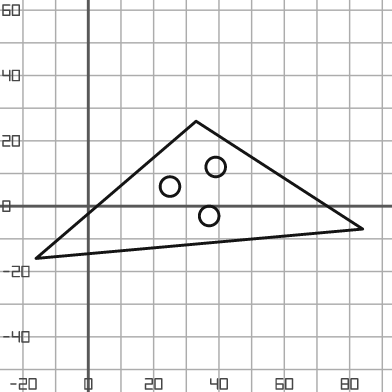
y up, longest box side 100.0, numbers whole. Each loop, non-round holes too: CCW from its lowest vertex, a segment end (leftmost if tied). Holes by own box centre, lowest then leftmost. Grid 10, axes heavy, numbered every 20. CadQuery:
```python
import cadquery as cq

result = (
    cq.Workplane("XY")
    .moveTo(-16.0, -16.0)
    .lineTo(84.0, -7.0)
    .lineTo(33.0, 26.0)
    .close()
    .moveTo(37.0, -3.0)
    .circle(3.0)
    .moveTo(25.0, 6.0)
    .circle(3.0)
    .moveTo(39.0, 12.0)
    .circle(3.0)
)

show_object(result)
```